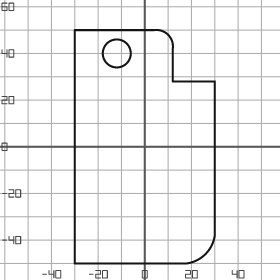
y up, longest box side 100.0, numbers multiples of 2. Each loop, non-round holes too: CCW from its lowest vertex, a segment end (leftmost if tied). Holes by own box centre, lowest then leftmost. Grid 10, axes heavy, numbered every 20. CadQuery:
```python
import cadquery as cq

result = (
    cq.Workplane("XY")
    .moveTo(-30.0, -50.0)
    .lineTo(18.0, -50.0)
    .threePointArc((26.0, -46.0), (30.0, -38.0))
    .lineTo(30.0, 28.0)
    .lineTo(12.0, 28.0)
    .lineTo(12.0, 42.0)
    .threePointArc((10.0, 48.0), (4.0, 50.0))
    .lineTo(-30.0, 50.0)
    .close()
    .moveTo(-12.0, 40.0)
    .circle(6.0)
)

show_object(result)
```